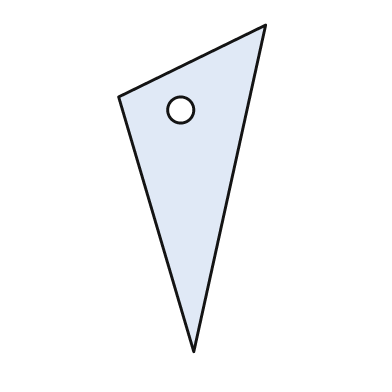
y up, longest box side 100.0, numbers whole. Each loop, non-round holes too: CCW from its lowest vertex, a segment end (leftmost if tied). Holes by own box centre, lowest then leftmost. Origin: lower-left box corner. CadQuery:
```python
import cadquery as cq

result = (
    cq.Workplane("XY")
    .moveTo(23.0, 0.0)
    .lineTo(45.0, 100.0)
    .lineTo(0.0, 78.0)
    .close()
    .moveTo(19.0, 74.0)
    .circle(4.0)
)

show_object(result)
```